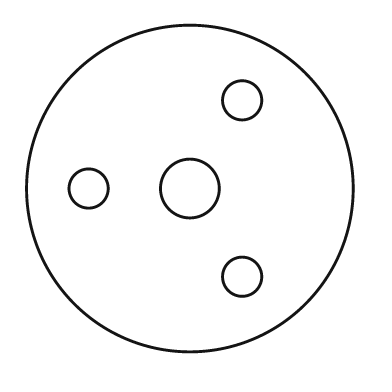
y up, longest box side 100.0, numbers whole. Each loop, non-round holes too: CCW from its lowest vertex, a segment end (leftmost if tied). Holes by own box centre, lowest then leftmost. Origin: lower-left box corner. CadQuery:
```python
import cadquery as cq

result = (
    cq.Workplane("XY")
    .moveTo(50.0, 50.0)
    .circle(50.0)
    .moveTo(66.0, 23.0)
    .circle(6.0)
    .moveTo(19.0, 50.0)
    .circle(6.0)
    .moveTo(50.0, 50.0)
    .circle(9.0)
    .moveTo(66.0, 77.0)
    .circle(6.0)
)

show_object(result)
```